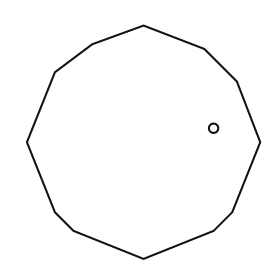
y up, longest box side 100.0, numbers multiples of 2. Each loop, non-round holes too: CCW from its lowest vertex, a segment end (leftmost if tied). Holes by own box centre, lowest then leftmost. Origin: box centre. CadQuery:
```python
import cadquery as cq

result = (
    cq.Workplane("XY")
    .moveTo(0.0, -50.0)
    .lineTo(30.0, -38.0)
    .lineTo(38.0, -30.0)
    .lineTo(50.0, 0.0)
    .lineTo(40.0, 26.0)
    .lineTo(26.0, 40.0)
    .lineTo(0.0, 50.0)
    .lineTo(-22.0, 42.0)
    .lineTo(-38.0, 30.0)
    .lineTo(-50.0, 0.0)
    .lineTo(-38.0, -30.0)
    .lineTo(-30.0, -38.0)
    .close()
    .moveTo(30.0, 6.0)
    .circle(2.0)
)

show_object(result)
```